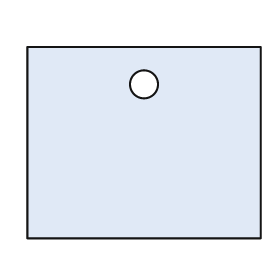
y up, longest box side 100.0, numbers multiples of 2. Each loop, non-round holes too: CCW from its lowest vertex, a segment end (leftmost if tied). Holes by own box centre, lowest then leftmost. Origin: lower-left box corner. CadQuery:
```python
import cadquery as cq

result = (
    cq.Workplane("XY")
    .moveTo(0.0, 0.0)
    .lineTo(100.0, 0.0)
    .lineTo(100.0, 82.0)
    .lineTo(0.0, 82.0)
    .close()
    .moveTo(50.0, 66.0)
    .circle(6.0)
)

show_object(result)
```